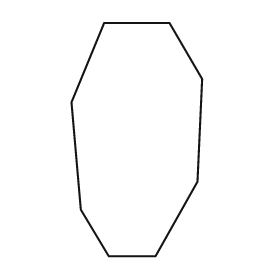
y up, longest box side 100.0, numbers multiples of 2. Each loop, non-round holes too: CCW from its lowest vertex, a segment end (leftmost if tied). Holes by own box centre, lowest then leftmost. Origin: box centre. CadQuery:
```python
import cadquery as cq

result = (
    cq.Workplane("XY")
    .moveTo(-12.0, -50.0)
    .lineTo(8.0, -50.0)
    .lineTo(26.0, -18.0)
    .lineTo(28.0, 26.0)
    .lineTo(14.0, 50.0)
    .lineTo(-14.0, 50.0)
    .lineTo(-28.0, 16.0)
    .lineTo(-24.0, -30.0)
    .close()
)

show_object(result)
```